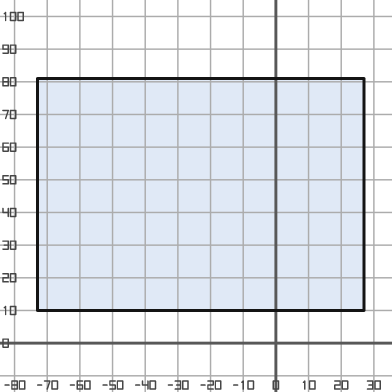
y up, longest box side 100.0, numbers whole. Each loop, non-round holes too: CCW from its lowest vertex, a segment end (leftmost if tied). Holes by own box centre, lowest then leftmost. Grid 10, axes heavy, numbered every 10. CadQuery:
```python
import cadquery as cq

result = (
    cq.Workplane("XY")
    .moveTo(-73.0, 10.0)
    .lineTo(27.0, 10.0)
    .lineTo(27.0, 81.0)
    .lineTo(-73.0, 81.0)
    .close()
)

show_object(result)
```